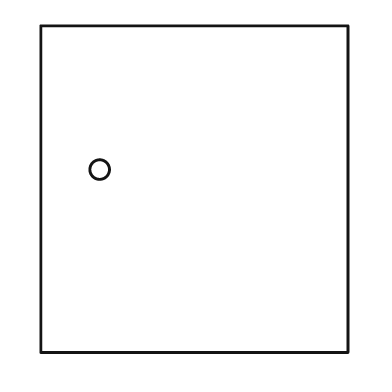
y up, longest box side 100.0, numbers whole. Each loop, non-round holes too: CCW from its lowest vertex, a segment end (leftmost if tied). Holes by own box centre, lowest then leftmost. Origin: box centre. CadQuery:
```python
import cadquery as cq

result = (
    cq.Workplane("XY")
    .moveTo(-47.0, -50.0)
    .lineTo(47.0, -50.0)
    .lineTo(47.0, 50.0)
    .lineTo(-47.0, 50.0)
    .close()
    .moveTo(-29.0, 6.0)
    .circle(3.0)
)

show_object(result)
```